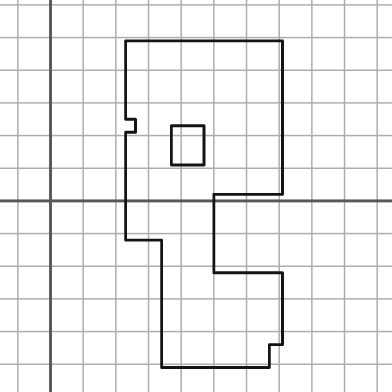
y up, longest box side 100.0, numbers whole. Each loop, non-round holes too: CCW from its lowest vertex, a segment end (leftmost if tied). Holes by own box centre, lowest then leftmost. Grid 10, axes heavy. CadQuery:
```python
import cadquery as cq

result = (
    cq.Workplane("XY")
    .moveTo(34.0, -51.0)
    .lineTo(67.0, -51.0)
    .lineTo(67.0, -44.0)
    .lineTo(71.0, -44.0)
    .lineTo(71.0, -22.0)
    .lineTo(50.0, -22.0)
    .lineTo(50.0, 2.0)
    .lineTo(71.0, 2.0)
    .lineTo(71.0, 49.0)
    .lineTo(23.0, 49.0)
    .lineTo(23.0, 25.0)
    .lineTo(26.0, 25.0)
    .lineTo(26.0, 21.0)
    .lineTo(23.0, 21.0)
    .lineTo(23.0, -12.0)
    .lineTo(34.0, -12.0)
    .close()
    .moveTo(37.0, 11.0)
    .lineTo(47.0, 11.0)
    .lineTo(47.0, 23.0)
    .lineTo(37.0, 23.0)
    .close()
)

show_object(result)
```